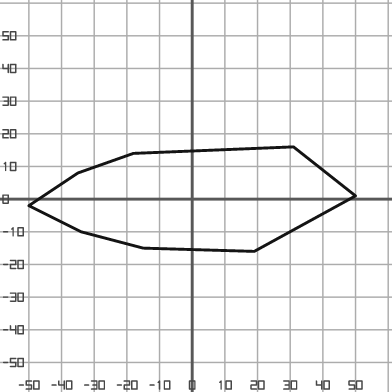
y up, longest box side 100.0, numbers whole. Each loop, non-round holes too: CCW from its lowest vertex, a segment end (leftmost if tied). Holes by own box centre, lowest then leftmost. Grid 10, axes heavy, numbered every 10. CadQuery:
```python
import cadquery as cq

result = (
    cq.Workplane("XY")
    .moveTo(19.0, -16.0)
    .lineTo(50.0, 1.0)
    .lineTo(31.0, 16.0)
    .lineTo(-18.0, 14.0)
    .lineTo(-35.0, 8.0)
    .lineTo(-50.0, -2.0)
    .lineTo(-34.0, -10.0)
    .lineTo(-15.0, -15.0)
    .close()
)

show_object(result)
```